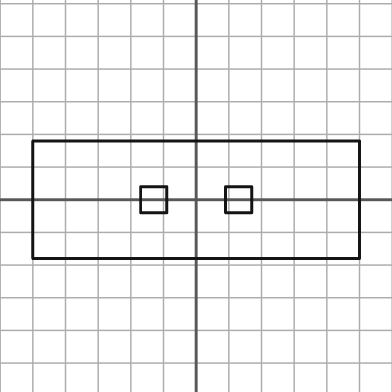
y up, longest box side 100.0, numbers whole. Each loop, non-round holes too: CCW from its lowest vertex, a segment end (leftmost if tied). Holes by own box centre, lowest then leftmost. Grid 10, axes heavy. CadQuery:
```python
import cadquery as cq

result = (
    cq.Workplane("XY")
    .moveTo(-50.0, -18.0)
    .lineTo(50.0, -18.0)
    .lineTo(50.0, 18.0)
    .lineTo(-50.0, 18.0)
    .close()
    .moveTo(-17.0, -4.0)
    .lineTo(-9.0, -4.0)
    .lineTo(-9.0, 4.0)
    .lineTo(-17.0, 4.0)
    .close()
    .moveTo(9.0, -4.0)
    .lineTo(17.0, -4.0)
    .lineTo(17.0, 4.0)
    .lineTo(9.0, 4.0)
    .close()
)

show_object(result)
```